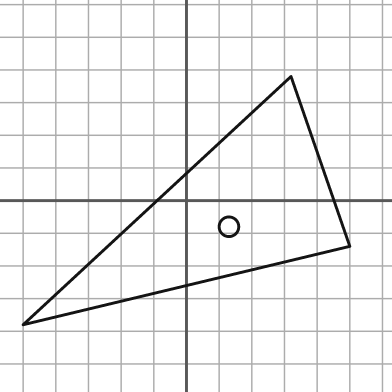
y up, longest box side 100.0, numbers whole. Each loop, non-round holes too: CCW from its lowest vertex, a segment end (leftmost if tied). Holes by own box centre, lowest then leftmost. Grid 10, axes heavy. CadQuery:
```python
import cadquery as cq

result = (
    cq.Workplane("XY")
    .moveTo(-50.0, -38.0)
    .lineTo(50.0, -14.0)
    .lineTo(32.0, 38.0)
    .close()
    .moveTo(13.0, -8.0)
    .circle(3.0)
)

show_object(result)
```